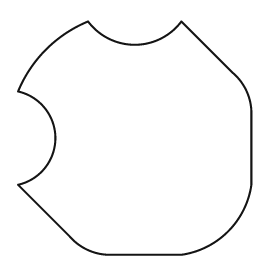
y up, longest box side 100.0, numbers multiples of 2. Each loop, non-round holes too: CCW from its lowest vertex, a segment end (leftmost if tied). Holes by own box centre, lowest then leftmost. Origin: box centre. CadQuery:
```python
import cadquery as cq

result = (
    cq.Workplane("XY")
    .moveTo(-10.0, -50.0)
    .lineTo(20.0, -50.0)
    .threePointArc((40.0, -40.0), (50.0, -20.0))
    .lineTo(50.0, 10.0)
    .threePointArc((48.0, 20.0), (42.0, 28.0))
    .lineTo(20.0, 50.0)
    .threePointArc((0.0, 40.0), (-20.0, 50.0))
    .threePointArc((-38.0, 38.0), (-50.0, 20.0))
    .threePointArc((-34.0, 0.0), (-50.0, -20.0))
    .lineTo(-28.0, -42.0)
    .threePointArc((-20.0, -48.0), (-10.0, -50.0))
    .close()
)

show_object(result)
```